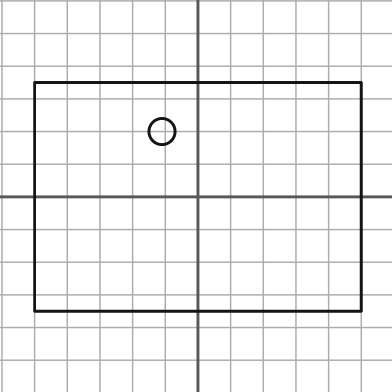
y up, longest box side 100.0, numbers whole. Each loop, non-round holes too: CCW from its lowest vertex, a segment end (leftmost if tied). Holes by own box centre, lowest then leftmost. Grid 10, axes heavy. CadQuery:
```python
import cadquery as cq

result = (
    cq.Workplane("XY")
    .moveTo(-50.0, -35.0)
    .lineTo(50.0, -35.0)
    .lineTo(50.0, 35.0)
    .lineTo(-50.0, 35.0)
    .close()
    .moveTo(-11.0, 20.0)
    .circle(4.0)
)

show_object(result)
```